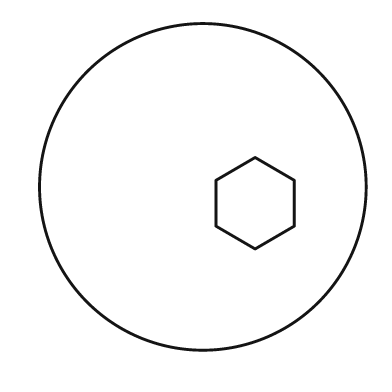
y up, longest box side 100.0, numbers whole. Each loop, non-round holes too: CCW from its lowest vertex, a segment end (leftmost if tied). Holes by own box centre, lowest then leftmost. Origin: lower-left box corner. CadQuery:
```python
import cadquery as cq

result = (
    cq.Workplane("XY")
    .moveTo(50.0, 50.0)
    .circle(50.0)
    .moveTo(66.0, 31.0)
    .lineTo(78.0, 38.0)
    .lineTo(78.0, 52.0)
    .lineTo(66.0, 59.0)
    .lineTo(54.0, 52.0)
    .lineTo(54.0, 38.0)
    .close()
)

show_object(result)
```